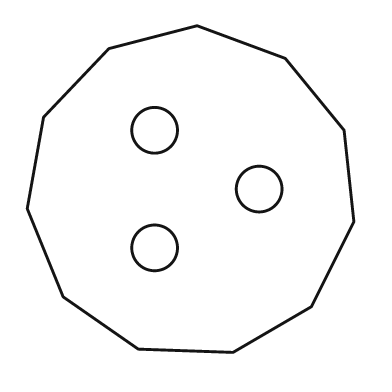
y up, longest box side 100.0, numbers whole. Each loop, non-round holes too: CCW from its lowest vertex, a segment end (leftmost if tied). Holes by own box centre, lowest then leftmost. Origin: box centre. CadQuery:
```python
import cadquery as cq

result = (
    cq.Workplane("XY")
    .moveTo(13.0, -50.0)
    .lineTo(37.0, -36.0)
    .lineTo(50.0, -10.0)
    .lineTo(47.0, 18.0)
    .lineTo(29.0, 40.0)
    .lineTo(2.0, 50.0)
    .lineTo(-25.0, 43.0)
    .lineTo(-45.0, 22.0)
    .lineTo(-50.0, -6.0)
    .lineTo(-39.0, -33.0)
    .lineTo(-16.0, -49.0)
    .close()
    .moveTo(-11.0, -18.0)
    .circle(7.0)
    .moveTo(21.0, 0.0)
    .circle(7.0)
    .moveTo(-11.0, 18.0)
    .circle(7.0)
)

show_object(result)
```